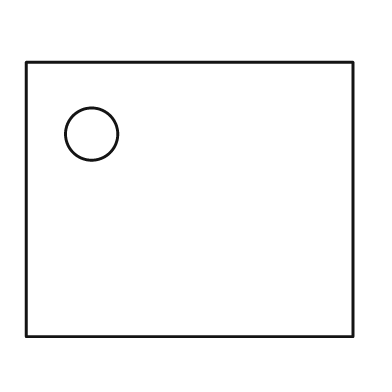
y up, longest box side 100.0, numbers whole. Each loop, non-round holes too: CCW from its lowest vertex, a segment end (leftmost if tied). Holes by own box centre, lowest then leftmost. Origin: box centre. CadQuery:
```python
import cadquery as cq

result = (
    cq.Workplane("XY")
    .moveTo(-50.0, -42.0)
    .lineTo(50.0, -42.0)
    .lineTo(50.0, 42.0)
    .lineTo(-50.0, 42.0)
    .close()
    .moveTo(-30.0, 20.0)
    .circle(8.0)
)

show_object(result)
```